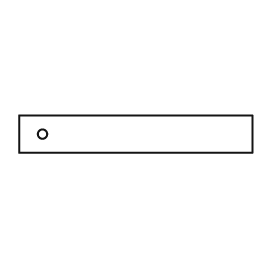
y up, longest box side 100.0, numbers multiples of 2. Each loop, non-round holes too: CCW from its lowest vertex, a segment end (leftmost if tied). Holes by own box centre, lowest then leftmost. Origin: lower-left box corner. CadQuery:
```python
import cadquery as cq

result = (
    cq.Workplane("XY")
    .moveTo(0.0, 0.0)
    .lineTo(100.0, 0.0)
    .lineTo(100.0, 16.0)
    .lineTo(0.0, 16.0)
    .close()
    .moveTo(10.0, 8.0)
    .circle(2.0)
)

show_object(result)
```